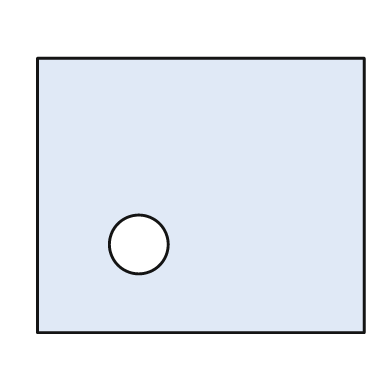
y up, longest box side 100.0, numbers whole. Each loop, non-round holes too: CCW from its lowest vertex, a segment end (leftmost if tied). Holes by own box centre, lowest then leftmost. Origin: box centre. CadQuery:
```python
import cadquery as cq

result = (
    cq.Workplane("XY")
    .moveTo(-50.0, -42.0)
    .lineTo(50.0, -42.0)
    .lineTo(50.0, 42.0)
    .lineTo(-50.0, 42.0)
    .close()
    .moveTo(-19.0, -15.0)
    .circle(9.0)
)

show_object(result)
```